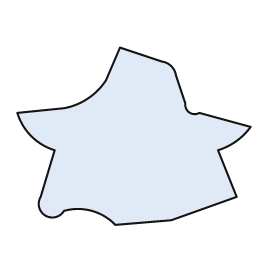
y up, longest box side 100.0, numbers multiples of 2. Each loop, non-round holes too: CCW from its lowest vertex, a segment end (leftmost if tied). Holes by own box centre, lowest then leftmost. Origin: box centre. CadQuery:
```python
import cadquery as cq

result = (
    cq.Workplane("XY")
    .moveTo(-8.0, -38.0)
    .lineTo(16.0, -36.0)
    .lineTo(44.0, -26.0)
    .lineTo(36.0, -6.0)
    .threePointArc((44.0, -2.0), (50.0, 4.0))
    .lineTo(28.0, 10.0)
    .threePointArc((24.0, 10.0), (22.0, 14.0))
    .lineTo(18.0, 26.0)
    .threePointArc((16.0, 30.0), (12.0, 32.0))
    .lineTo(-6.0, 38.0)
    .lineTo(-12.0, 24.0)
    .threePointArc((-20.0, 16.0), (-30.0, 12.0))
    .lineTo(-50.0, 10.0)
    .threePointArc((-44.0, 0.0), (-34.0, -6.0))
    .lineTo(-40.0, -26.0)
    .threePointArc((-38.0, -34.0), (-30.0, -32.0))
    .threePointArc((-18.0, -32.0), (-8.0, -38.0))
    .close()
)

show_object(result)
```